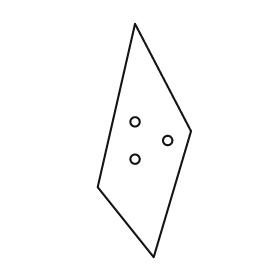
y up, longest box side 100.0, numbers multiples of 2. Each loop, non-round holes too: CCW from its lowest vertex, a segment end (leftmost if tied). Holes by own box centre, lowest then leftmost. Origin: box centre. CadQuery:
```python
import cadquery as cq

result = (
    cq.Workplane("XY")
    .moveTo(4.0, -50.0)
    .lineTo(20.0, 4.0)
    .lineTo(-4.0, 50.0)
    .lineTo(-20.0, -20.0)
    .close()
    .moveTo(-4.0, -8.0)
    .circle(2.0)
    .moveTo(10.0, 0.0)
    .circle(2.0)
    .moveTo(-4.0, 8.0)
    .circle(2.0)
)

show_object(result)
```